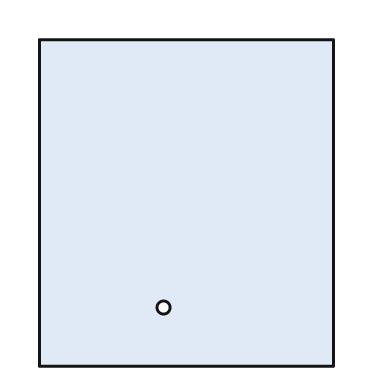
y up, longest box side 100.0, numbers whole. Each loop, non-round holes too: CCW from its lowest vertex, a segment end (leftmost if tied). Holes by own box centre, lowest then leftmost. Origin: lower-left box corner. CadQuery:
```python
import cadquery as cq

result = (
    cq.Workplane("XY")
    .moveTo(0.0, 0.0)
    .lineTo(90.0, 0.0)
    .lineTo(90.0, 100.0)
    .lineTo(0.0, 100.0)
    .close()
    .moveTo(38.0, 18.0)
    .circle(2.0)
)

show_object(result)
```